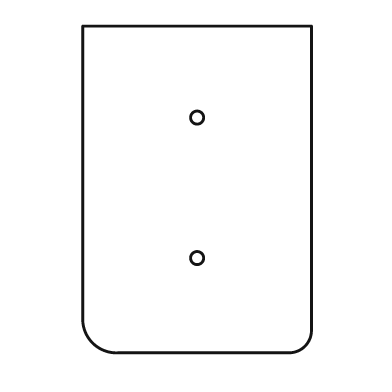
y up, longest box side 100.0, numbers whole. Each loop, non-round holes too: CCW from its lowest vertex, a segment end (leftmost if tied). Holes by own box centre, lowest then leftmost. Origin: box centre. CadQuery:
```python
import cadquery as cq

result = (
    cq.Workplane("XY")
    .moveTo(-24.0, -50.0)
    .lineTo(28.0, -50.0)
    .threePointArc((33.0, -48.0), (35.0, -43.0))
    .lineTo(35.0, 50.0)
    .lineTo(-35.0, 50.0)
    .lineTo(-35.0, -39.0)
    .threePointArc((-32.0, -47.0), (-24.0, -50.0))
    .close()
    .moveTo(0.0, -21.0)
    .circle(2.0)
    .moveTo(0.0, 22.0)
    .circle(2.0)
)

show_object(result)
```